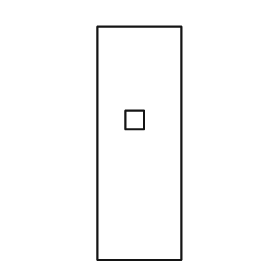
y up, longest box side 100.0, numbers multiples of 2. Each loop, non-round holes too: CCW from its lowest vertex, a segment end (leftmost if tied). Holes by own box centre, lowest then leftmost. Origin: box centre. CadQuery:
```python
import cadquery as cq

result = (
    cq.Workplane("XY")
    .moveTo(-18.0, -50.0)
    .lineTo(18.0, -50.0)
    .lineTo(18.0, 50.0)
    .lineTo(-18.0, 50.0)
    .close()
    .moveTo(-6.0, 6.0)
    .lineTo(2.0, 6.0)
    .lineTo(2.0, 14.0)
    .lineTo(-6.0, 14.0)
    .close()
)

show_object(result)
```